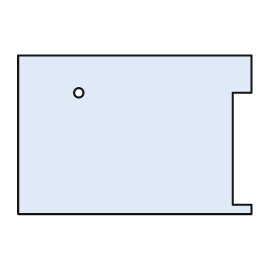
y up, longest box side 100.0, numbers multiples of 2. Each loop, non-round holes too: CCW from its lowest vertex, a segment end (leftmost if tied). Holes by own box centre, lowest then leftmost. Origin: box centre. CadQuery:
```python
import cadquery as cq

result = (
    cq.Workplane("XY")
    .moveTo(-50.0, -34.0)
    .lineTo(50.0, -34.0)
    .lineTo(50.0, -30.0)
    .lineTo(42.0, -30.0)
    .lineTo(42.0, 18.0)
    .lineTo(50.0, 18.0)
    .lineTo(50.0, 34.0)
    .lineTo(-50.0, 34.0)
    .close()
    .moveTo(-24.0, 18.0)
    .circle(2.0)
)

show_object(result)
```